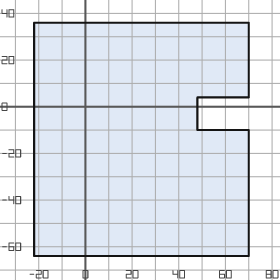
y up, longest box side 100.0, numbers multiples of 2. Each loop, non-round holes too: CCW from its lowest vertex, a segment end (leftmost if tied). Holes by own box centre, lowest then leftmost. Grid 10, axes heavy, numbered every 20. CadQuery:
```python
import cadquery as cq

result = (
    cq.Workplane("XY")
    .moveTo(-22.0, -64.0)
    .lineTo(70.0, -64.0)
    .lineTo(70.0, -10.0)
    .lineTo(48.0, -10.0)
    .lineTo(48.0, 4.0)
    .lineTo(70.0, 4.0)
    .lineTo(70.0, 36.0)
    .lineTo(-22.0, 36.0)
    .close()
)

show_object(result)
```